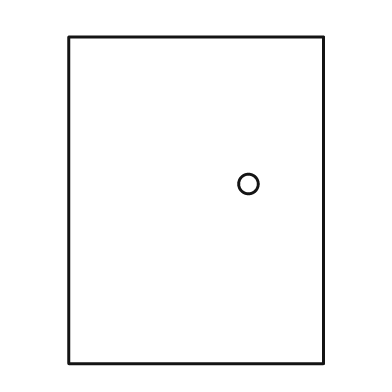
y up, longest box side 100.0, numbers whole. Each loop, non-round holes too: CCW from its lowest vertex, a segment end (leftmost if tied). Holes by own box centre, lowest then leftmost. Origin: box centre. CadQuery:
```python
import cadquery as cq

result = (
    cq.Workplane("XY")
    .moveTo(-39.0, -50.0)
    .lineTo(39.0, -50.0)
    .lineTo(39.0, 50.0)
    .lineTo(-39.0, 50.0)
    .close()
    .moveTo(16.0, 5.0)
    .circle(3.0)
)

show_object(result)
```